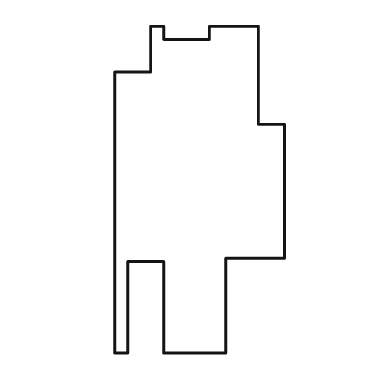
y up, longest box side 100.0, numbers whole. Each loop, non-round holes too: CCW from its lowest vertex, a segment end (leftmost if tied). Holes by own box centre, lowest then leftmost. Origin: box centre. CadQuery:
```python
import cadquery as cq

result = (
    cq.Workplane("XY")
    .moveTo(-26.0, -50.0)
    .lineTo(-22.0, -50.0)
    .lineTo(-22.0, -22.0)
    .lineTo(-11.0, -22.0)
    .lineTo(-11.0, -50.0)
    .lineTo(8.0, -50.0)
    .lineTo(8.0, -21.0)
    .lineTo(26.0, -21.0)
    .lineTo(26.0, 20.0)
    .lineTo(18.0, 20.0)
    .lineTo(18.0, 50.0)
    .lineTo(3.0, 50.0)
    .lineTo(3.0, 46.0)
    .lineTo(-11.0, 46.0)
    .lineTo(-11.0, 50.0)
    .lineTo(-15.0, 50.0)
    .lineTo(-15.0, 36.0)
    .lineTo(-26.0, 36.0)
    .close()
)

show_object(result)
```